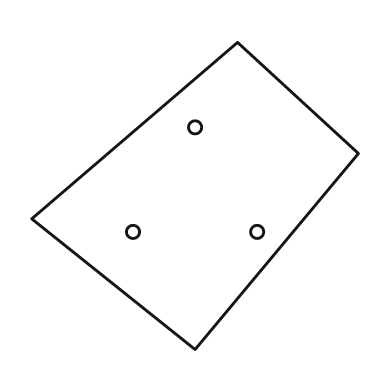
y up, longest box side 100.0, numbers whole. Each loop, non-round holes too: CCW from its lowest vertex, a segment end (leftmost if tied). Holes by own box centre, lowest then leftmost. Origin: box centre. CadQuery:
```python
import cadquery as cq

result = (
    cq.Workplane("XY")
    .moveTo(0.0, -47.0)
    .lineTo(50.0, 13.0)
    .lineTo(13.0, 47.0)
    .lineTo(-50.0, -7.0)
    .close()
    .moveTo(-19.0, -11.0)
    .circle(2.0)
    .moveTo(19.0, -11.0)
    .circle(2.0)
    .moveTo(0.0, 21.0)
    .circle(2.0)
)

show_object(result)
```